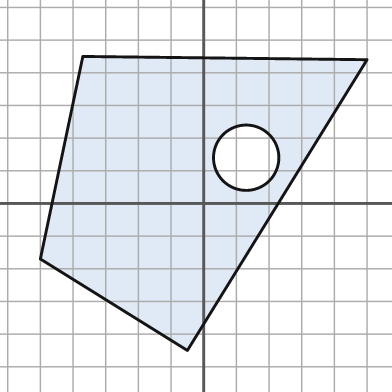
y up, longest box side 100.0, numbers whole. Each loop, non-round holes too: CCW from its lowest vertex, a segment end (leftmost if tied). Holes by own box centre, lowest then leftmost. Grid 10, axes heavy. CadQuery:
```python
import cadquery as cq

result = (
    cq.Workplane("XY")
    .moveTo(-5.0, -45.0)
    .lineTo(50.0, 44.0)
    .lineTo(-37.0, 45.0)
    .lineTo(-50.0, -17.0)
    .close()
    .moveTo(13.0, 14.0)
    .circle(10.0)
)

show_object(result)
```